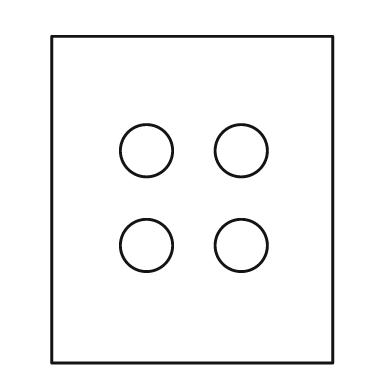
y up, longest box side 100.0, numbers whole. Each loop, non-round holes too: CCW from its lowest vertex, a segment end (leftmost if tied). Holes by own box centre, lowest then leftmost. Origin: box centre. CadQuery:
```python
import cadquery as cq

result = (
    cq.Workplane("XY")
    .moveTo(-43.0, -50.0)
    .lineTo(43.0, -50.0)
    .lineTo(43.0, 50.0)
    .lineTo(-43.0, 50.0)
    .close()
    .moveTo(-14.0, -14.0)
    .circle(8.0)
    .moveTo(15.0, -14.0)
    .circle(8.0)
    .moveTo(-14.0, 15.0)
    .circle(8.0)
    .moveTo(15.0, 15.0)
    .circle(8.0)
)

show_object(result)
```